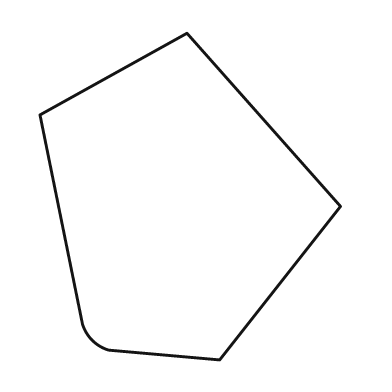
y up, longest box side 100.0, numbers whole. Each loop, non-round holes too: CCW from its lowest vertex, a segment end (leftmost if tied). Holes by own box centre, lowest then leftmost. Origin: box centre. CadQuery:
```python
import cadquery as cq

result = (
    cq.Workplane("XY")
    .moveTo(9.0, -50.0)
    .lineTo(46.0, -3.0)
    .lineTo(-1.0, 50.0)
    .lineTo(-46.0, 25.0)
    .lineTo(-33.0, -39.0)
    .threePointArc((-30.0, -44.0), (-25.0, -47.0))
    .close()
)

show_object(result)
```